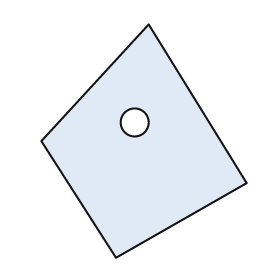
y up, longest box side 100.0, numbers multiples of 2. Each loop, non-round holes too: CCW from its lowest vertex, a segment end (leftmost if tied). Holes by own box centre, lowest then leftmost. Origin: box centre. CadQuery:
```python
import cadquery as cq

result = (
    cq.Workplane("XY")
    .moveTo(-12.0, -50.0)
    .lineTo(44.0, -18.0)
    .lineTo(2.0, 50.0)
    .lineTo(-44.0, 0.0)
    .close()
    .moveTo(-4.0, 8.0)
    .circle(6.0)
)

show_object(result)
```